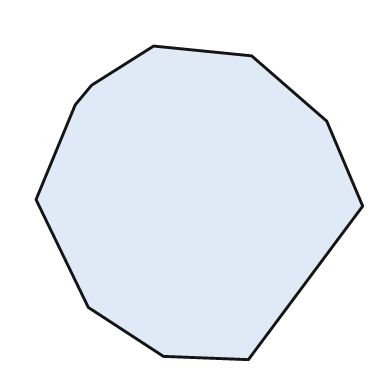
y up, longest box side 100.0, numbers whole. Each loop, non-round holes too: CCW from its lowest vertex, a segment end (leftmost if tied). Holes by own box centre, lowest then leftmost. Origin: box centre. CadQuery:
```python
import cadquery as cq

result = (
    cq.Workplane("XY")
    .moveTo(15.0, -48.0)
    .lineTo(50.0, -1.0)
    .lineTo(39.0, 25.0)
    .lineTo(16.0, 45.0)
    .lineTo(-14.0, 48.0)
    .lineTo(-33.0, 36.0)
    .lineTo(-38.0, 30.0)
    .lineTo(-50.0, 1.0)
    .lineTo(-34.0, -32.0)
    .lineTo(-11.0, -47.0)
    .close()
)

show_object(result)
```